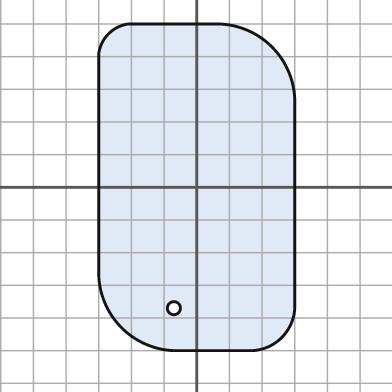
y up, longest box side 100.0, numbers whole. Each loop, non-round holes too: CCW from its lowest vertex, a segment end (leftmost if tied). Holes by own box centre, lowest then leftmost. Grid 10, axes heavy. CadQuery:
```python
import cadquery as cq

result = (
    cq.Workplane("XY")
    .moveTo(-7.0, -50.0)
    .lineTo(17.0, -50.0)
    .threePointArc((26.0, -46.0), (30.0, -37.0))
    .lineTo(30.0, 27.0)
    .threePointArc((23.0, 43.0), (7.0, 50.0))
    .lineTo(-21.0, 50.0)
    .threePointArc((-27.0, 47.0), (-30.0, 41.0))
    .lineTo(-30.0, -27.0)
    .threePointArc((-23.0, -43.0), (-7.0, -50.0))
    .close()
    .moveTo(-7.0, -37.0)
    .circle(2.0)
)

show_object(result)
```